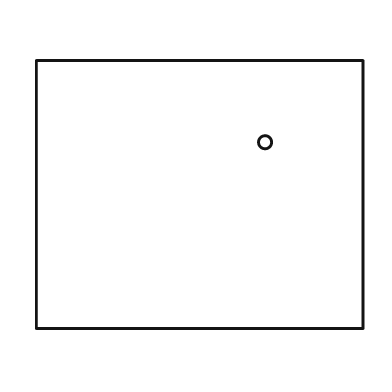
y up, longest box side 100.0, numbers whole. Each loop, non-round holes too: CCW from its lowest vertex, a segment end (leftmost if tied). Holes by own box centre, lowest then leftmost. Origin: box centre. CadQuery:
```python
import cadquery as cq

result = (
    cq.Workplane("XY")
    .moveTo(-50.0, -41.0)
    .lineTo(50.0, -41.0)
    .lineTo(50.0, 41.0)
    .lineTo(-50.0, 41.0)
    .close()
    .moveTo(20.0, 16.0)
    .circle(2.0)
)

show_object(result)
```